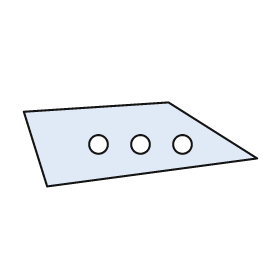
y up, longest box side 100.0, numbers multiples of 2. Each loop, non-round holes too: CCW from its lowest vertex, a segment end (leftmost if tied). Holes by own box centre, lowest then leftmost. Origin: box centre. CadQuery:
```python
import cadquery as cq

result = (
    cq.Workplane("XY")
    .moveTo(-40.0, -18.0)
    .lineTo(50.0, -6.0)
    .lineTo(12.0, 18.0)
    .lineTo(-50.0, 14.0)
    .close()
    .moveTo(-18.0, 0.0)
    .circle(4.0)
    .moveTo(0.0, 0.0)
    .circle(4.0)
    .moveTo(18.0, 0.0)
    .circle(4.0)
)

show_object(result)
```